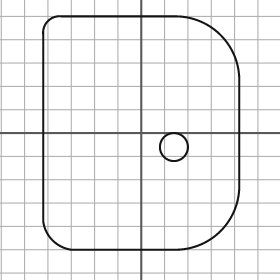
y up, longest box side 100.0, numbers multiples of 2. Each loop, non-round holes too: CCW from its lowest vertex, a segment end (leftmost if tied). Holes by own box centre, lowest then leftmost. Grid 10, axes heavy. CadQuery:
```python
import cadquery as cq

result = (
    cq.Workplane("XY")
    .moveTo(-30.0, -50.0)
    .lineTo(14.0, -50.0)
    .threePointArc((34.0, -42.0), (42.0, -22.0))
    .lineTo(42.0, 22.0)
    .threePointArc((34.0, 42.0), (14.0, 50.0))
    .lineTo(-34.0, 50.0)
    .threePointArc((-40.0, 48.0), (-42.0, 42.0))
    .lineTo(-42.0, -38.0)
    .threePointArc((-38.0, -46.0), (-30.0, -50.0))
    .close()
    .moveTo(14.0, -6.0)
    .circle(6.0)
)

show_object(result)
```